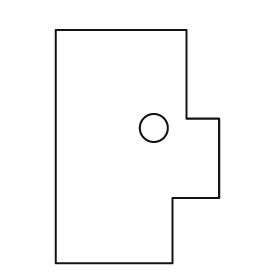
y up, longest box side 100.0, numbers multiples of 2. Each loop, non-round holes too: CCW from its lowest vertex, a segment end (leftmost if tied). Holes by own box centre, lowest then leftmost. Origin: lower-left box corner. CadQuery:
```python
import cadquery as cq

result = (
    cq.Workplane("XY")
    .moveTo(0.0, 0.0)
    .lineTo(50.0, 0.0)
    .lineTo(50.0, 28.0)
    .lineTo(70.0, 28.0)
    .lineTo(70.0, 62.0)
    .lineTo(56.0, 62.0)
    .lineTo(56.0, 100.0)
    .lineTo(0.0, 100.0)
    .close()
    .moveTo(42.0, 58.0)
    .circle(6.0)
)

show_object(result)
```